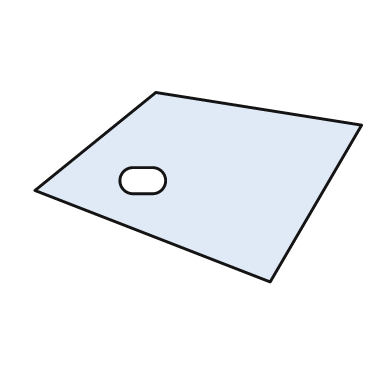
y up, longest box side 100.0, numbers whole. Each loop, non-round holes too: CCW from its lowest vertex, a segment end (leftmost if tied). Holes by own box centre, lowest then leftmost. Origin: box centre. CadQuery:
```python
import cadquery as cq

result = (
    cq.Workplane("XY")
    .moveTo(22.0, -29.0)
    .lineTo(50.0, 19.0)
    .lineTo(-13.0, 29.0)
    .lineTo(-50.0, -1.0)
    .close()
    .moveTo(-20.0, -2.0)
    .lineTo(-14.0, -2.0)
    .threePointArc((-10.0, 2.0), (-14.0, 6.0))
    .lineTo(-20.0, 6.0)
    .threePointArc((-24.0, 2.0), (-20.0, -2.0))
    .close()
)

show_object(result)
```